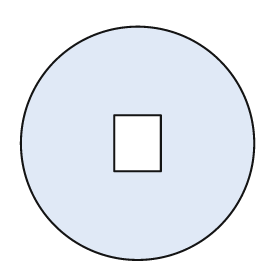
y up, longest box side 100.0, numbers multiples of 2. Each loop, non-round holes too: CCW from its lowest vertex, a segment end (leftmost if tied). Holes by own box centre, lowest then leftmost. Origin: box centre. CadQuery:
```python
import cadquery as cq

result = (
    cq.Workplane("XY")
    .moveTo(0.0, 0.0)
    .circle(50.0)
    .moveTo(-10.0, -12.0)
    .lineTo(10.0, -12.0)
    .lineTo(10.0, 12.0)
    .lineTo(-10.0, 12.0)
    .close()
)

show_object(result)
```